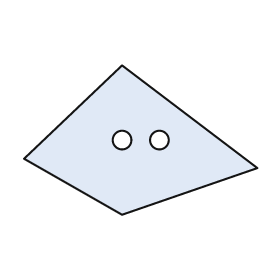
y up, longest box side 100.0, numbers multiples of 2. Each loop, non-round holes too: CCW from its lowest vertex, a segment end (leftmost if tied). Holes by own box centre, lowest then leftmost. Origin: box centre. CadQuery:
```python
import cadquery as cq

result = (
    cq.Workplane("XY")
    .moveTo(-8.0, -32.0)
    .lineTo(50.0, -12.0)
    .lineTo(-8.0, 32.0)
    .lineTo(-50.0, -8.0)
    .close()
    .moveTo(-8.0, 0.0)
    .circle(4.0)
    .moveTo(8.0, 0.0)
    .circle(4.0)
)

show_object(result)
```